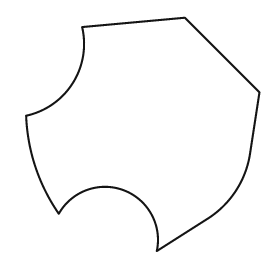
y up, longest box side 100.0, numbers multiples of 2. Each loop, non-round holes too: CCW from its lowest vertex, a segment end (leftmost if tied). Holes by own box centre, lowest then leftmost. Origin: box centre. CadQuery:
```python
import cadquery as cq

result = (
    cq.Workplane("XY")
    .moveTo(6.0, -50.0)
    .lineTo(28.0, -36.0)
    .threePointArc((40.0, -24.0), (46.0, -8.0))
    .lineTo(50.0, 18.0)
    .lineTo(18.0, 50.0)
    .lineTo(-26.0, 46.0)
    .threePointArc((-30.0, 22.0), (-50.0, 8.0))
    .threePointArc((-46.0, -14.0), (-36.0, -34.0))
    .threePointArc((-8.0, -24.0), (6.0, -50.0))
    .close()
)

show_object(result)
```